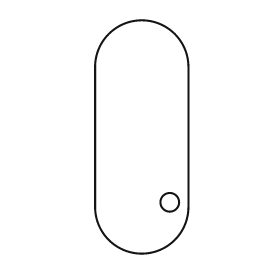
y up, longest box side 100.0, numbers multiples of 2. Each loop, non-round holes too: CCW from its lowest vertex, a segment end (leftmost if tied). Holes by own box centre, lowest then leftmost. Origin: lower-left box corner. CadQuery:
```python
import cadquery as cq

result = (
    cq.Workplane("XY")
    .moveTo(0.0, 20.0)
    .threePointArc((20.0, 0.0), (40.0, 20.0))
    .lineTo(40.0, 80.0)
    .threePointArc((20.0, 100.0), (0.0, 80.0))
    .close()
    .moveTo(32.0, 22.0)
    .circle(4.0)
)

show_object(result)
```